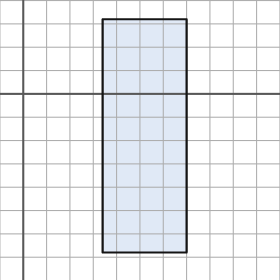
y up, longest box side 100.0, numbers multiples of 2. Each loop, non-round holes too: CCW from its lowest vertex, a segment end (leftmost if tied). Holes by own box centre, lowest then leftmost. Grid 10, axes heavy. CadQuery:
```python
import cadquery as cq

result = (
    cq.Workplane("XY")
    .moveTo(34.0, -68.0)
    .lineTo(70.0, -68.0)
    .lineTo(70.0, 32.0)
    .lineTo(34.0, 32.0)
    .close()
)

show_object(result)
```